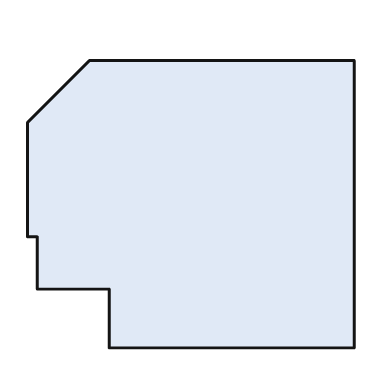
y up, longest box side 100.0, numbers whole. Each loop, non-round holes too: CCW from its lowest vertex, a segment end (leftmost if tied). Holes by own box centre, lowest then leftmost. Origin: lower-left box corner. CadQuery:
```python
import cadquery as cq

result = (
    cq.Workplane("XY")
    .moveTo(25.0, 0.0)
    .lineTo(100.0, 0.0)
    .lineTo(100.0, 88.0)
    .lineTo(19.0, 88.0)
    .lineTo(0.0, 69.0)
    .lineTo(0.0, 34.0)
    .lineTo(3.0, 34.0)
    .lineTo(3.0, 18.0)
    .lineTo(25.0, 18.0)
    .close()
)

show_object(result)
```